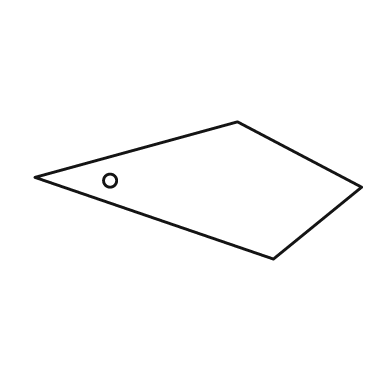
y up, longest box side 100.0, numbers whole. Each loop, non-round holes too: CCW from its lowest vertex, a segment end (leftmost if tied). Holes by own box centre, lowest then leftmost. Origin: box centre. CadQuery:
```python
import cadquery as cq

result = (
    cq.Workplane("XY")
    .moveTo(23.0, -21.0)
    .lineTo(50.0, 1.0)
    .lineTo(12.0, 21.0)
    .lineTo(-50.0, 4.0)
    .close()
    .moveTo(-27.0, 3.0)
    .circle(2.0)
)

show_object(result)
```